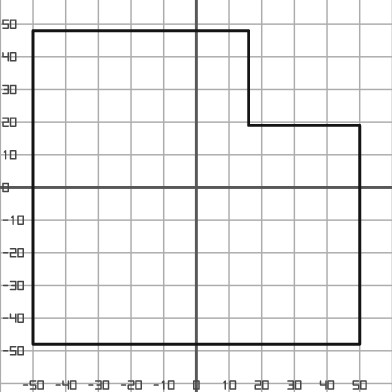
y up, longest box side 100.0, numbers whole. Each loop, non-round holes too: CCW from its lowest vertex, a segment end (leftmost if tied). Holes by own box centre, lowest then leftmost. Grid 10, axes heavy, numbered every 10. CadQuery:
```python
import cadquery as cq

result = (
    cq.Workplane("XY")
    .moveTo(-50.0, -48.0)
    .lineTo(50.0, -48.0)
    .lineTo(50.0, 19.0)
    .lineTo(16.0, 19.0)
    .lineTo(16.0, 48.0)
    .lineTo(-50.0, 48.0)
    .close()
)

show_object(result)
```